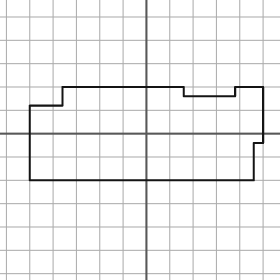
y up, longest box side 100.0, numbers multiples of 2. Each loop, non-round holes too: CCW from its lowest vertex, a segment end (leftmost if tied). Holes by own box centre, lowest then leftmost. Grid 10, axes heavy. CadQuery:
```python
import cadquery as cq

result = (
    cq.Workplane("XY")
    .moveTo(-50.0, -20.0)
    .lineTo(46.0, -20.0)
    .lineTo(46.0, -4.0)
    .lineTo(50.0, -4.0)
    .lineTo(50.0, 20.0)
    .lineTo(38.0, 20.0)
    .lineTo(38.0, 16.0)
    .lineTo(16.0, 16.0)
    .lineTo(16.0, 20.0)
    .lineTo(-36.0, 20.0)
    .lineTo(-36.0, 12.0)
    .lineTo(-50.0, 12.0)
    .close()
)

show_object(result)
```